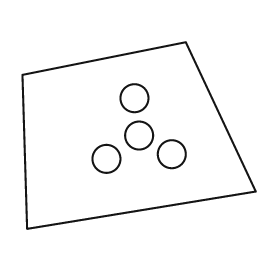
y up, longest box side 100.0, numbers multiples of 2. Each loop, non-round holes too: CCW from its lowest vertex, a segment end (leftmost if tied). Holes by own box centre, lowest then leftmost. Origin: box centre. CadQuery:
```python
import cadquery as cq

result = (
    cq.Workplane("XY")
    .moveTo(-48.0, -40.0)
    .lineTo(50.0, -24.0)
    .lineTo(20.0, 40.0)
    .lineTo(-50.0, 26.0)
    .close()
    .moveTo(-14.0, -10.0)
    .circle(6.0)
    .moveTo(14.0, -8.0)
    .circle(6.0)
    .moveTo(0.0, 0.0)
    .circle(6.0)
    .moveTo(-2.0, 16.0)
    .circle(6.0)
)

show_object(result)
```